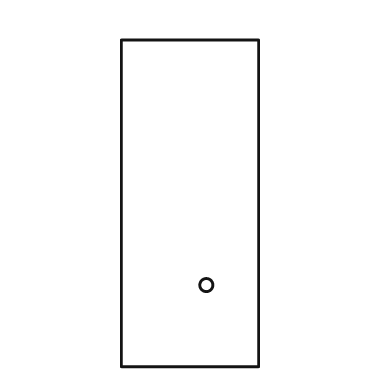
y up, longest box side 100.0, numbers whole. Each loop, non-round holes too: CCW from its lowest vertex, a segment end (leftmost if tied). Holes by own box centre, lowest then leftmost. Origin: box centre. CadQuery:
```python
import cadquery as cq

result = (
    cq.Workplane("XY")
    .moveTo(-21.0, -50.0)
    .lineTo(21.0, -50.0)
    .lineTo(21.0, 50.0)
    .lineTo(-21.0, 50.0)
    .close()
    .moveTo(5.0, -25.0)
    .circle(2.0)
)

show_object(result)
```